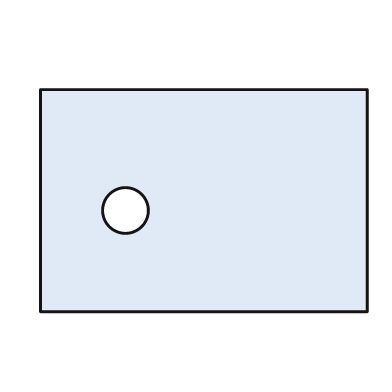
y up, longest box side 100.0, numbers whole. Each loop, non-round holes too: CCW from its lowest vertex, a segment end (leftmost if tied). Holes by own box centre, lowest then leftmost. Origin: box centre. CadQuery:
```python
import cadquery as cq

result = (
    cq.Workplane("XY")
    .moveTo(-50.0, -34.0)
    .lineTo(50.0, -34.0)
    .lineTo(50.0, 34.0)
    .lineTo(-50.0, 34.0)
    .close()
    .moveTo(-24.0, -3.0)
    .circle(7.0)
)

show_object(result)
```